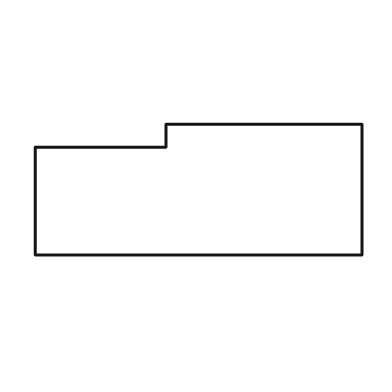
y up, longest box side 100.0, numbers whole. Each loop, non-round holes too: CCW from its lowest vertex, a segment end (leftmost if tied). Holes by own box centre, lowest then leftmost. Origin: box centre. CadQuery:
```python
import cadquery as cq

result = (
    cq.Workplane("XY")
    .moveTo(-50.0, -20.0)
    .lineTo(50.0, -20.0)
    .lineTo(50.0, 20.0)
    .lineTo(-10.0, 20.0)
    .lineTo(-10.0, 13.0)
    .lineTo(-50.0, 13.0)
    .close()
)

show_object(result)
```